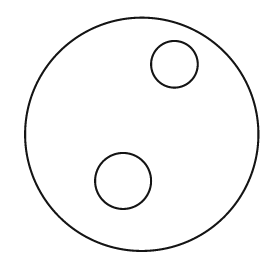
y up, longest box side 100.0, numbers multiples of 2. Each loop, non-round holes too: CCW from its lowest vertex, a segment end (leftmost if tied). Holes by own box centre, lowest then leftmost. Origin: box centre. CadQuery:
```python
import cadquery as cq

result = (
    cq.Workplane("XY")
    .moveTo(0.0, 0.0)
    .circle(50.0)
    .moveTo(-8.0, -20.0)
    .circle(12.0)
    .moveTo(14.0, 30.0)
    .circle(10.0)
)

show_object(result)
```